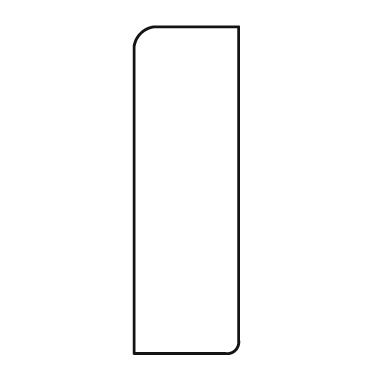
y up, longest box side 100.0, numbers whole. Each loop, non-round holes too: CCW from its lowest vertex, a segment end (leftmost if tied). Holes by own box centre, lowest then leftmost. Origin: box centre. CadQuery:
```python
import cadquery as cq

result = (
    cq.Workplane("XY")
    .moveTo(-16.0, -50.0)
    .lineTo(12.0, -50.0)
    .threePointArc((15.0, -49.0), (16.0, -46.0))
    .lineTo(16.0, 50.0)
    .lineTo(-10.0, 50.0)
    .threePointArc((-14.0, 48.0), (-16.0, 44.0))
    .close()
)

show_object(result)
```